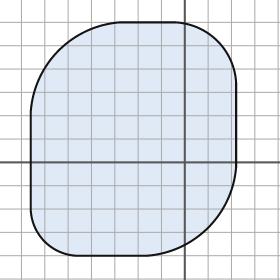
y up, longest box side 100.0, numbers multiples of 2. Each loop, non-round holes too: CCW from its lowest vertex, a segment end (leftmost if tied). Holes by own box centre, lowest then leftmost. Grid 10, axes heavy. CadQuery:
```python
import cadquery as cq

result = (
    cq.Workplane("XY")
    .moveTo(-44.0, -40.0)
    .lineTo(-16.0, -40.0)
    .threePointArc((10.0, -28.0), (22.0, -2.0))
    .lineTo(22.0, 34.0)
    .threePointArc((14.0, 52.0), (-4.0, 60.0))
    .lineTo(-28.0, 60.0)
    .threePointArc((-54.0, 48.0), (-66.0, 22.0))
    .lineTo(-66.0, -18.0)
    .threePointArc((-60.0, -34.0), (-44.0, -40.0))
    .close()
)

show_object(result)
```